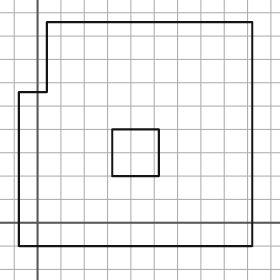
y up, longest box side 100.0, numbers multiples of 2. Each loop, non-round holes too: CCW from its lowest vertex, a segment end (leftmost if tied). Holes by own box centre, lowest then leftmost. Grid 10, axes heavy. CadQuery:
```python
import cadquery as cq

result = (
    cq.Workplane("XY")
    .moveTo(-8.0, -10.0)
    .lineTo(92.0, -10.0)
    .lineTo(92.0, 86.0)
    .lineTo(4.0, 86.0)
    .lineTo(4.0, 56.0)
    .lineTo(-8.0, 56.0)
    .close()
    .moveTo(32.0, 20.0)
    .lineTo(52.0, 20.0)
    .lineTo(52.0, 40.0)
    .lineTo(32.0, 40.0)
    .close()
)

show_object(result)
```